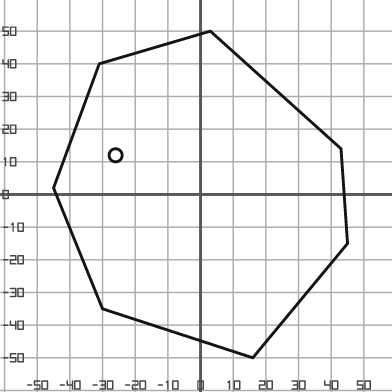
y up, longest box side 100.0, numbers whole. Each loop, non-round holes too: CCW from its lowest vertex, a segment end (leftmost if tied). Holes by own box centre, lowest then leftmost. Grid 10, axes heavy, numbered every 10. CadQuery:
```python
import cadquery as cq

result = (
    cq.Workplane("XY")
    .moveTo(16.0, -50.0)
    .lineTo(45.0, -15.0)
    .lineTo(43.0, 14.0)
    .lineTo(3.0, 50.0)
    .lineTo(-31.0, 40.0)
    .lineTo(-45.0, 2.0)
    .lineTo(-30.0, -35.0)
    .close()
    .moveTo(-26.0, 12.0)
    .circle(2.0)
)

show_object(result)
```